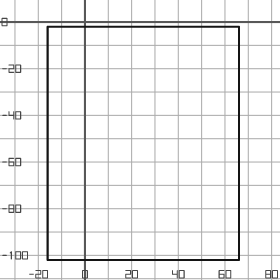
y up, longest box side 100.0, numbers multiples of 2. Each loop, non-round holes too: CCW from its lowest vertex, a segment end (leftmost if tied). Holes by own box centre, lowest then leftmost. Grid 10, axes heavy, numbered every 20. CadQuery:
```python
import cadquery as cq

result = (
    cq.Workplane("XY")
    .moveTo(-16.0, -102.0)
    .lineTo(66.0, -102.0)
    .lineTo(66.0, -2.0)
    .lineTo(-16.0, -2.0)
    .close()
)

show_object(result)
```